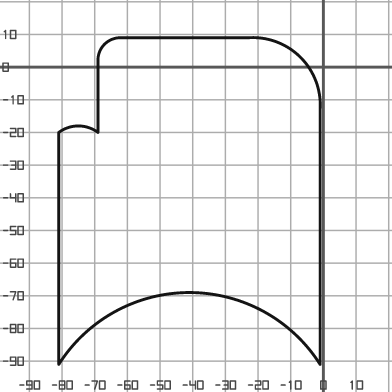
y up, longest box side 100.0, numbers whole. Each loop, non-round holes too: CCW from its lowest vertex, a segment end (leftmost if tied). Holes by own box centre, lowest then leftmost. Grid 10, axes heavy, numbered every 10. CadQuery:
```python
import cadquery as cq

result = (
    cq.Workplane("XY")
    .moveTo(-81.0, -91.0)
    .threePointArc((-41.0, -69.0), (-1.0, -91.0))
    .lineTo(-1.0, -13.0)
    .threePointArc((-7.0, 3.0), (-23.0, 9.0))
    .lineTo(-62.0, 9.0)
    .threePointArc((-67.0, 7.0), (-69.0, 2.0))
    .lineTo(-69.0, -20.0)
    .threePointArc((-75.0, -18.0), (-81.0, -20.0))
    .close()
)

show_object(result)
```